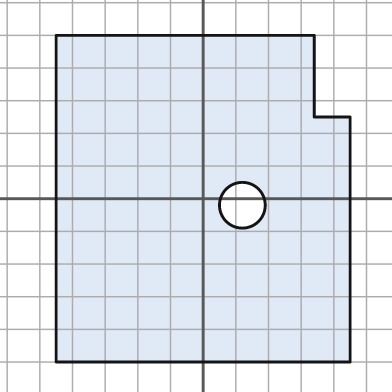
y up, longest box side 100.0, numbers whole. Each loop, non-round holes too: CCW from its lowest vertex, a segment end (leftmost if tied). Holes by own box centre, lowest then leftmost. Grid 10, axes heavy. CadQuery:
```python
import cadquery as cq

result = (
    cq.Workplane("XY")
    .moveTo(-45.0, -50.0)
    .lineTo(45.0, -50.0)
    .lineTo(45.0, 25.0)
    .lineTo(34.0, 25.0)
    .lineTo(34.0, 50.0)
    .lineTo(-45.0, 50.0)
    .close()
    .moveTo(12.0, -2.0)
    .circle(7.0)
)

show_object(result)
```